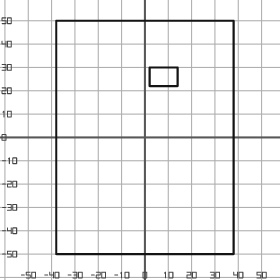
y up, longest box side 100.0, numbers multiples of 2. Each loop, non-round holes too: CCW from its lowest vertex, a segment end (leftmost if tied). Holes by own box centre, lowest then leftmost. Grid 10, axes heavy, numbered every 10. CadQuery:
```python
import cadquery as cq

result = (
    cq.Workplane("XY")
    .moveTo(-38.0, -50.0)
    .lineTo(38.0, -50.0)
    .lineTo(38.0, 50.0)
    .lineTo(-38.0, 50.0)
    .close()
    .moveTo(2.0, 22.0)
    .lineTo(14.0, 22.0)
    .lineTo(14.0, 30.0)
    .lineTo(2.0, 30.0)
    .close()
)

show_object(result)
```